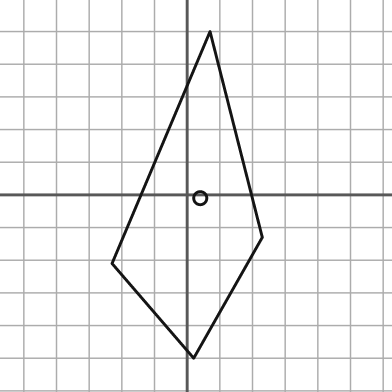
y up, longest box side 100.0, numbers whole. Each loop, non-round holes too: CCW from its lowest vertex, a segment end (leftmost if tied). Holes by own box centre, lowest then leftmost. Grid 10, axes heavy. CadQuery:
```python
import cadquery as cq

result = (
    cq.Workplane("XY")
    .moveTo(2.0, -50.0)
    .lineTo(23.0, -13.0)
    .lineTo(7.0, 50.0)
    .lineTo(-23.0, -21.0)
    .close()
    .moveTo(4.0, -1.0)
    .circle(2.0)
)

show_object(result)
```